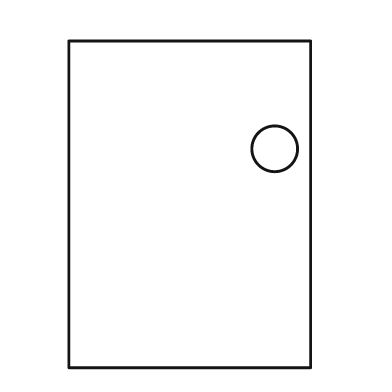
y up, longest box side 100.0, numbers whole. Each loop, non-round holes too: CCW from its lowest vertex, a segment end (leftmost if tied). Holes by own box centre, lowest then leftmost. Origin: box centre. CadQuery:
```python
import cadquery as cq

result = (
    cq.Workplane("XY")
    .moveTo(-37.0, -50.0)
    .lineTo(37.0, -50.0)
    .lineTo(37.0, 50.0)
    .lineTo(-37.0, 50.0)
    .close()
    .moveTo(26.0, 17.0)
    .circle(7.0)
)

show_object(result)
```